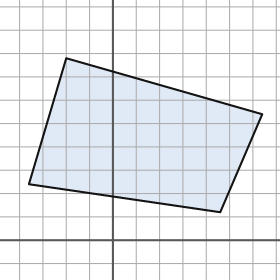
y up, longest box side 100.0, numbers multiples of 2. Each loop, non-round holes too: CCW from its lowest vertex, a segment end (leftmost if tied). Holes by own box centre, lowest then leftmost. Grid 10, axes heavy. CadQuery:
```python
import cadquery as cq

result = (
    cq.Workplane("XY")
    .moveTo(46.0, 12.0)
    .lineTo(64.0, 54.0)
    .lineTo(-20.0, 78.0)
    .lineTo(-36.0, 24.0)
    .close()
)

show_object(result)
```